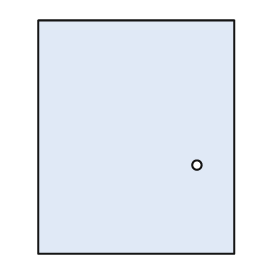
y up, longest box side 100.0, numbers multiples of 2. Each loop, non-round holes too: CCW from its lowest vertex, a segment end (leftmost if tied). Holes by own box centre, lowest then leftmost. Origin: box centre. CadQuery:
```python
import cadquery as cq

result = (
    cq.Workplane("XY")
    .moveTo(-42.0, -50.0)
    .lineTo(42.0, -50.0)
    .lineTo(42.0, 50.0)
    .lineTo(-42.0, 50.0)
    .close()
    .moveTo(26.0, -12.0)
    .circle(2.0)
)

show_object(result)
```